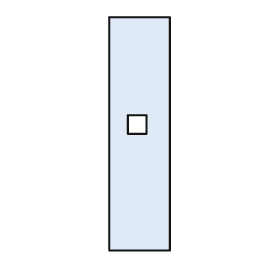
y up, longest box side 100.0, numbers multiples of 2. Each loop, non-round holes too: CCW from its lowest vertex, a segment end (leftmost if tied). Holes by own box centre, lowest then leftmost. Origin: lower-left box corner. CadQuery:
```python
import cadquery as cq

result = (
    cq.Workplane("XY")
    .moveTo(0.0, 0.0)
    .lineTo(26.0, 0.0)
    .lineTo(26.0, 100.0)
    .lineTo(0.0, 100.0)
    .close()
    .moveTo(8.0, 50.0)
    .lineTo(16.0, 50.0)
    .lineTo(16.0, 58.0)
    .lineTo(8.0, 58.0)
    .close()
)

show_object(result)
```